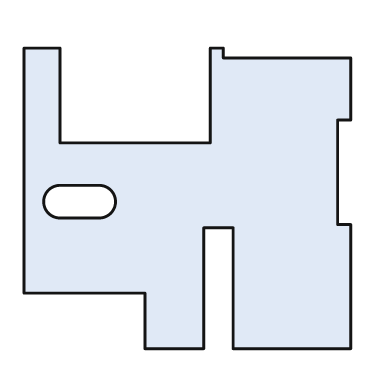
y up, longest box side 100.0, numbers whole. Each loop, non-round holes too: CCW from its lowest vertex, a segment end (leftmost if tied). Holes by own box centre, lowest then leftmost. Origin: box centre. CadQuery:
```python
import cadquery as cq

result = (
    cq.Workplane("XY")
    .moveTo(-13.0, -46.0)
    .lineTo(5.0, -46.0)
    .lineTo(5.0, -9.0)
    .lineTo(14.0, -9.0)
    .lineTo(14.0, -46.0)
    .lineTo(50.0, -46.0)
    .lineTo(50.0, -8.0)
    .lineTo(46.0, -8.0)
    .lineTo(46.0, 24.0)
    .lineTo(50.0, 24.0)
    .lineTo(50.0, 43.0)
    .lineTo(11.0, 43.0)
    .lineTo(11.0, 46.0)
    .lineTo(7.0, 46.0)
    .lineTo(7.0, 17.0)
    .lineTo(-39.0, 17.0)
    .lineTo(-39.0, 46.0)
    .lineTo(-50.0, 46.0)
    .lineTo(-50.0, -29.0)
    .lineTo(-13.0, -29.0)
    .close()
    .moveTo(-39.0, -6.0)
    .lineTo(-27.0, -6.0)
    .threePointArc((-22.0, -1.0), (-27.0, 4.0))
    .lineTo(-39.0, 4.0)
    .threePointArc((-44.0, -1.0), (-39.0, -6.0))
    .close()
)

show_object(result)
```